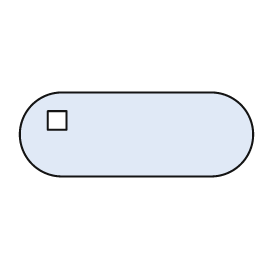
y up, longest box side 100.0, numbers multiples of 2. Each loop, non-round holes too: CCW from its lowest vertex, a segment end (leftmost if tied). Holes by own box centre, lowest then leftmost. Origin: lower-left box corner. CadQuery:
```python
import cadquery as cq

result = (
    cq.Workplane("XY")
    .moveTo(18.0, 0.0)
    .lineTo(82.0, 0.0)
    .threePointArc((100.0, 18.0), (82.0, 36.0))
    .lineTo(18.0, 36.0)
    .threePointArc((0.0, 18.0), (18.0, 0.0))
    .close()
    .moveTo(12.0, 20.0)
    .lineTo(20.0, 20.0)
    .lineTo(20.0, 28.0)
    .lineTo(12.0, 28.0)
    .close()
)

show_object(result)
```